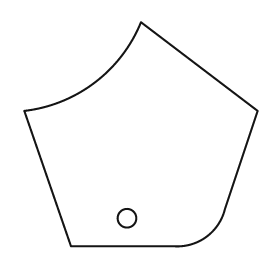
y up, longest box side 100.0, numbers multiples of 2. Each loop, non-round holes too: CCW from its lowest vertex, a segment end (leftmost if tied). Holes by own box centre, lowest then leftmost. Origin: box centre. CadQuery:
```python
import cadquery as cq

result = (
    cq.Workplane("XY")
    .moveTo(-30.0, -48.0)
    .lineTo(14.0, -48.0)
    .threePointArc((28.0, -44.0), (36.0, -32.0))
    .lineTo(50.0, 10.0)
    .lineTo(0.0, 48.0)
    .threePointArc((-20.0, 22.0), (-50.0, 10.0))
    .close()
    .moveTo(-6.0, -36.0)
    .circle(4.0)
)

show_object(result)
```